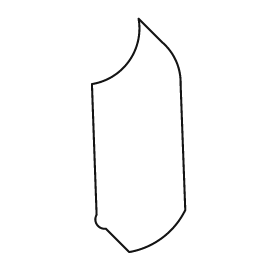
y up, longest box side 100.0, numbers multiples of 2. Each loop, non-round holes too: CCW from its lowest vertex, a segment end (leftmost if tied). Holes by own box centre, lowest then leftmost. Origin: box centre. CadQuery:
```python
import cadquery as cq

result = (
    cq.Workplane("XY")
    .moveTo(-4.0, -50.0)
    .threePointArc((10.0, -44.0), (20.0, -32.0))
    .lineTo(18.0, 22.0)
    .threePointArc((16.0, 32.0), (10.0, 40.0))
    .lineTo(0.0, 50.0)
    .threePointArc((-4.0, 32.0), (-20.0, 22.0))
    .lineTo(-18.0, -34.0)
    .threePointArc((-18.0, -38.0), (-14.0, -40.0))
    .close()
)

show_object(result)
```